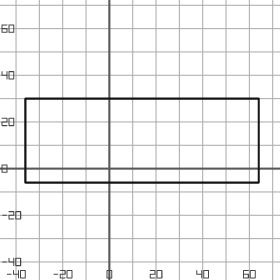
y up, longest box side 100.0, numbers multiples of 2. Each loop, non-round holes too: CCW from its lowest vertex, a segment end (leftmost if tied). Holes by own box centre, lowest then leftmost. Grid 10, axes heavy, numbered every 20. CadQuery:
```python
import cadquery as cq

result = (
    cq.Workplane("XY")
    .moveTo(-36.0, -6.0)
    .lineTo(64.0, -6.0)
    .lineTo(64.0, 30.0)
    .lineTo(-36.0, 30.0)
    .close()
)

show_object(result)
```